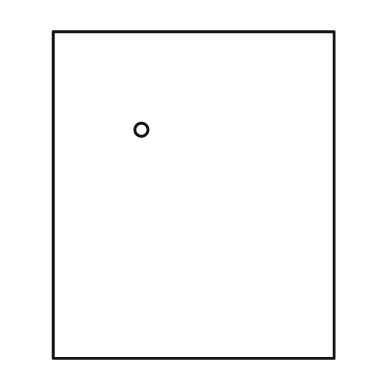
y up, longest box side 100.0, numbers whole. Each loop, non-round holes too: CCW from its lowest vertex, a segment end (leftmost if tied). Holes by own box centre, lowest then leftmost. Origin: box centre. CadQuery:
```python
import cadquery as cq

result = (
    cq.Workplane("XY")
    .moveTo(-43.0, -50.0)
    .lineTo(43.0, -50.0)
    .lineTo(43.0, 50.0)
    .lineTo(-43.0, 50.0)
    .close()
    .moveTo(-16.0, 20.0)
    .circle(2.0)
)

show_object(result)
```